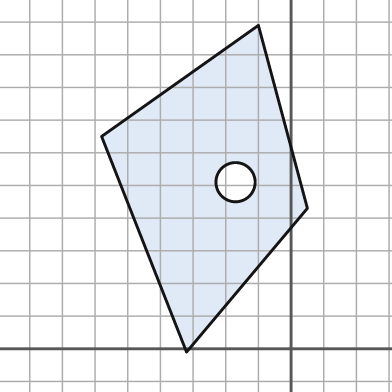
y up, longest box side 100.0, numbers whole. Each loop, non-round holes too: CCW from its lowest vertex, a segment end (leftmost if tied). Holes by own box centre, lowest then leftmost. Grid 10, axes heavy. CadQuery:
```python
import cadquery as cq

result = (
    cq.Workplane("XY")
    .moveTo(-32.0, -1.0)
    .lineTo(5.0, 43.0)
    .lineTo(-10.0, 99.0)
    .lineTo(-58.0, 65.0)
    .close()
    .moveTo(-17.0, 51.0)
    .circle(6.0)
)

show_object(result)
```